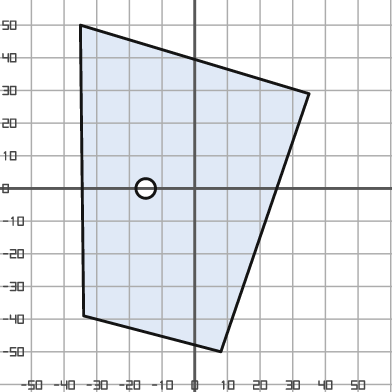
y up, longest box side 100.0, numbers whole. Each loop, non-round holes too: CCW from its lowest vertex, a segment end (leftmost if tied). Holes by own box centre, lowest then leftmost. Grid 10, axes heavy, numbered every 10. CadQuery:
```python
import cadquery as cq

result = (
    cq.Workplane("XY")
    .moveTo(8.0, -50.0)
    .lineTo(35.0, 29.0)
    .lineTo(-35.0, 50.0)
    .lineTo(-34.0, -39.0)
    .close()
    .moveTo(-15.0, 0.0)
    .circle(3.0)
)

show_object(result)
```